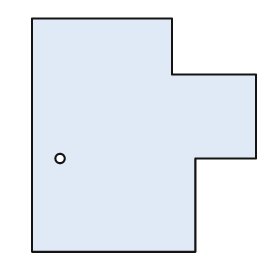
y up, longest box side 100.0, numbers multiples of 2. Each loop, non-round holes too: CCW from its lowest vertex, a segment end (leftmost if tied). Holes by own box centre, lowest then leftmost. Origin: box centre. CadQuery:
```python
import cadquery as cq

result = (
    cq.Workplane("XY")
    .moveTo(-48.0, -50.0)
    .lineTo(22.0, -50.0)
    .lineTo(22.0, -10.0)
    .lineTo(48.0, -10.0)
    .lineTo(48.0, 26.0)
    .lineTo(12.0, 26.0)
    .lineTo(12.0, 50.0)
    .lineTo(-48.0, 50.0)
    .close()
    .moveTo(-36.0, -10.0)
    .circle(2.0)
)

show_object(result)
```